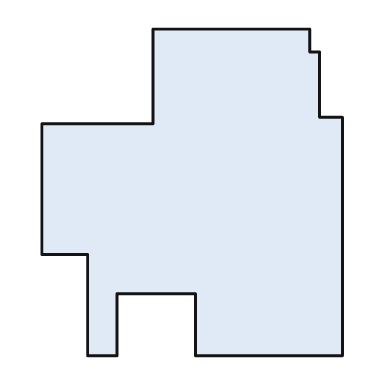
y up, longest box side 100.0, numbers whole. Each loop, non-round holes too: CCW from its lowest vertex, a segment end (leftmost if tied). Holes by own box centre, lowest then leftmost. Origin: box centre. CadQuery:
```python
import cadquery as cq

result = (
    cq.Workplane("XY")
    .moveTo(-32.0, -50.0)
    .lineTo(-23.0, -50.0)
    .lineTo(-23.0, -31.0)
    .lineTo(1.0, -31.0)
    .lineTo(1.0, -50.0)
    .lineTo(46.0, -50.0)
    .lineTo(46.0, 23.0)
    .lineTo(39.0, 23.0)
    .lineTo(39.0, 43.0)
    .lineTo(36.0, 43.0)
    .lineTo(36.0, 50.0)
    .lineTo(-12.0, 50.0)
    .lineTo(-12.0, 21.0)
    .lineTo(-46.0, 21.0)
    .lineTo(-46.0, -19.0)
    .lineTo(-32.0, -19.0)
    .close()
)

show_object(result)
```